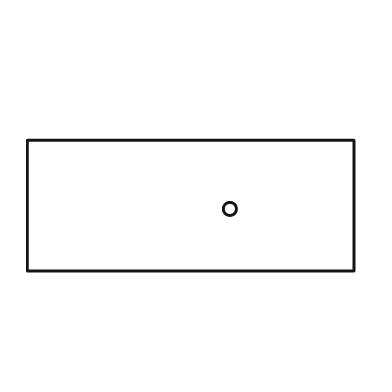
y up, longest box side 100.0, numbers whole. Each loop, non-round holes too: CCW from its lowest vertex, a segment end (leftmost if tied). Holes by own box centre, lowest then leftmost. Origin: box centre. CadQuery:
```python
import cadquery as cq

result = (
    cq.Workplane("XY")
    .moveTo(-50.0, -20.0)
    .lineTo(50.0, -20.0)
    .lineTo(50.0, 20.0)
    .lineTo(-50.0, 20.0)
    .close()
    .moveTo(12.0, -1.0)
    .circle(2.0)
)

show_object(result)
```